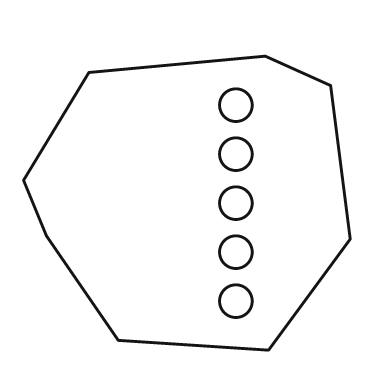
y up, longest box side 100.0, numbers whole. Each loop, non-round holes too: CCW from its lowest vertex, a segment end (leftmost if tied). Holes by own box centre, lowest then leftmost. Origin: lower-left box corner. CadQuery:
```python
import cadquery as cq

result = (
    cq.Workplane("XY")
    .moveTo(75.0, 0.0)
    .lineTo(100.0, 34.0)
    .lineTo(94.0, 81.0)
    .lineTo(74.0, 90.0)
    .lineTo(20.0, 85.0)
    .lineTo(0.0, 52.0)
    .lineTo(7.0, 35.0)
    .lineTo(29.0, 3.0)
    .close()
    .moveTo(65.0, 15.0)
    .circle(5.0)
    .moveTo(65.0, 30.0)
    .circle(5.0)
    .moveTo(65.0, 45.0)
    .circle(5.0)
    .moveTo(65.0, 60.0)
    .circle(5.0)
    .moveTo(65.0, 75.0)
    .circle(5.0)
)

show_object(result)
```